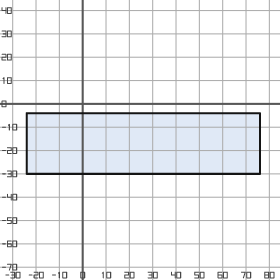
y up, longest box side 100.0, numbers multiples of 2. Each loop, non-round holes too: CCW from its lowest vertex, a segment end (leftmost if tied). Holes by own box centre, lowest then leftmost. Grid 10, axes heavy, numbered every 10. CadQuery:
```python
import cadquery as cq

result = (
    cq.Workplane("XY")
    .moveTo(-24.0, -30.0)
    .lineTo(76.0, -30.0)
    .lineTo(76.0, -4.0)
    .lineTo(-24.0, -4.0)
    .close()
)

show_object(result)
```